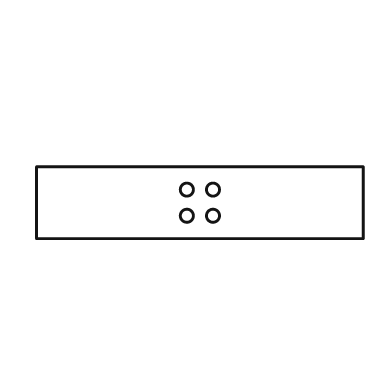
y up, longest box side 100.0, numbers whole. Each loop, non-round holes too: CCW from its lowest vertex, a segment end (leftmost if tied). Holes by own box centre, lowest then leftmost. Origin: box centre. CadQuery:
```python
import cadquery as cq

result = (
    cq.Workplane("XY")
    .moveTo(-50.0, -11.0)
    .lineTo(50.0, -11.0)
    .lineTo(50.0, 11.0)
    .lineTo(-50.0, 11.0)
    .close()
    .moveTo(-4.0, -4.0)
    .circle(2.0)
    .moveTo(4.0, -4.0)
    .circle(2.0)
    .moveTo(-4.0, 4.0)
    .circle(2.0)
    .moveTo(4.0, 4.0)
    .circle(2.0)
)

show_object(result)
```